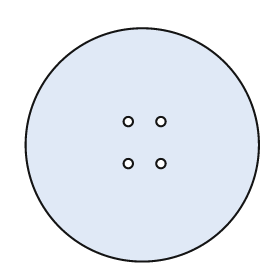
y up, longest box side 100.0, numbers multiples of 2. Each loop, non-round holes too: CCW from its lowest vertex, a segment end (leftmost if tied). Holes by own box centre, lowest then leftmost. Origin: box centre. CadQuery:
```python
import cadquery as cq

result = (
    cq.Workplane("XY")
    .moveTo(0.0, 0.0)
    .circle(50.0)
    .moveTo(-6.0, -8.0)
    .circle(2.0)
    .moveTo(8.0, -8.0)
    .circle(2.0)
    .moveTo(-6.0, 10.0)
    .circle(2.0)
    .moveTo(8.0, 10.0)
    .circle(2.0)
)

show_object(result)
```